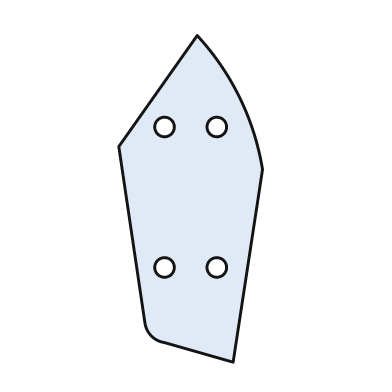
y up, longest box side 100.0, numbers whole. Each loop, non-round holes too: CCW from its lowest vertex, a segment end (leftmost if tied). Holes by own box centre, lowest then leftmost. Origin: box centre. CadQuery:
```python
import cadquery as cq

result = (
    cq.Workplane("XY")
    .moveTo(13.0, -50.0)
    .lineTo(22.0, 9.0)
    .threePointArc((15.0, 31.0), (2.0, 50.0))
    .lineTo(-22.0, 16.0)
    .lineTo(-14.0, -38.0)
    .threePointArc((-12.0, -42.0), (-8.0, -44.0))
    .close()
    .moveTo(-8.0, -21.0)
    .circle(3.0)
    .moveTo(8.0, -21.0)
    .circle(3.0)
    .moveTo(-8.0, 22.0)
    .circle(3.0)
    .moveTo(8.0, 22.0)
    .circle(3.0)
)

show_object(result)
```